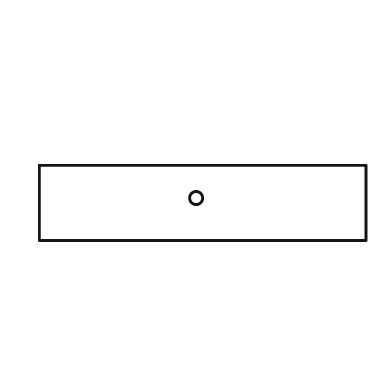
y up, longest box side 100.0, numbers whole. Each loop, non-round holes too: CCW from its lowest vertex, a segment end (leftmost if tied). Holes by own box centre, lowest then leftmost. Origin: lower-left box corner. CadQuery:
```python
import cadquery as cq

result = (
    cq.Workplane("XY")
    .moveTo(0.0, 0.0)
    .lineTo(100.0, 0.0)
    .lineTo(100.0, 23.0)
    .lineTo(0.0, 23.0)
    .close()
    .moveTo(48.0, 13.0)
    .circle(2.0)
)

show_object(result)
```